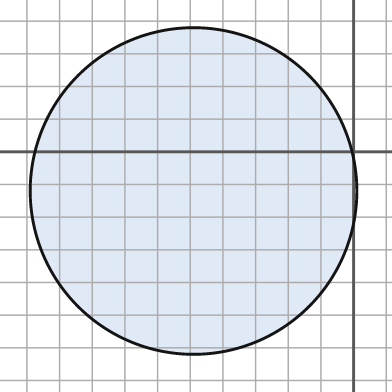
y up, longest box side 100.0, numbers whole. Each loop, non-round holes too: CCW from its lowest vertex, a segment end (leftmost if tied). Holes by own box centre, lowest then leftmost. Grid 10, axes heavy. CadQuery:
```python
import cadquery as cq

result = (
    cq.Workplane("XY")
    .moveTo(-49.0, -12.0)
    .circle(50.0)
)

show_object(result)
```